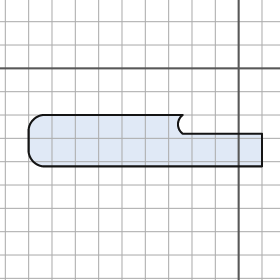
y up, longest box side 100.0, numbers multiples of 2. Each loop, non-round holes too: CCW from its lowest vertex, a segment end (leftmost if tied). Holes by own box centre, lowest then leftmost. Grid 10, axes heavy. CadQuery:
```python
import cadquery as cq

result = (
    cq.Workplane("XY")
    .moveTo(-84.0, -42.0)
    .lineTo(10.0, -42.0)
    .lineTo(10.0, -28.0)
    .lineTo(-24.0, -28.0)
    .threePointArc((-26.0, -24.0), (-24.0, -20.0))
    .lineTo(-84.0, -20.0)
    .threePointArc((-88.0, -22.0), (-90.0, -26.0))
    .lineTo(-90.0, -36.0)
    .threePointArc((-88.0, -40.0), (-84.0, -42.0))
    .close()
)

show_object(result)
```